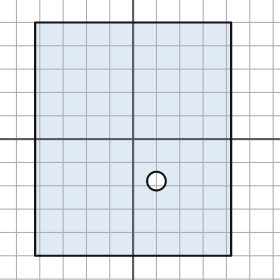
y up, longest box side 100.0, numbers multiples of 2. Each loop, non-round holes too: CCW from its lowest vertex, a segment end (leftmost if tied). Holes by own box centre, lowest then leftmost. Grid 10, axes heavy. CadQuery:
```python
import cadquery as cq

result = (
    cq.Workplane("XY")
    .moveTo(-42.0, -50.0)
    .lineTo(42.0, -50.0)
    .lineTo(42.0, 50.0)
    .lineTo(-42.0, 50.0)
    .close()
    .moveTo(10.0, -18.0)
    .circle(4.0)
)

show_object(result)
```